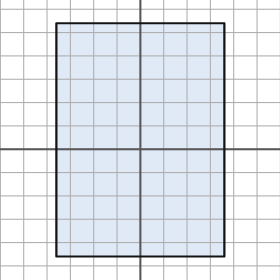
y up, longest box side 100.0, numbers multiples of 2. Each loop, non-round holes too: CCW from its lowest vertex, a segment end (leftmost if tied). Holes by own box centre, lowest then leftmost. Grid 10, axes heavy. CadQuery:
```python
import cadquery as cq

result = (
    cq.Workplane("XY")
    .moveTo(-36.0, -46.0)
    .lineTo(36.0, -46.0)
    .lineTo(36.0, 54.0)
    .lineTo(-36.0, 54.0)
    .close()
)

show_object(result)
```